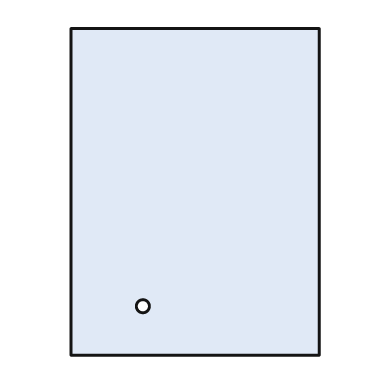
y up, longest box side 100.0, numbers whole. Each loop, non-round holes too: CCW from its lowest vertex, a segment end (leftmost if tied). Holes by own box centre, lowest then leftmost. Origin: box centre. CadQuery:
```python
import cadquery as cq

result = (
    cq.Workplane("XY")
    .moveTo(-38.0, -50.0)
    .lineTo(38.0, -50.0)
    .lineTo(38.0, 50.0)
    .lineTo(-38.0, 50.0)
    .close()
    .moveTo(-16.0, -35.0)
    .circle(2.0)
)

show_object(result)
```